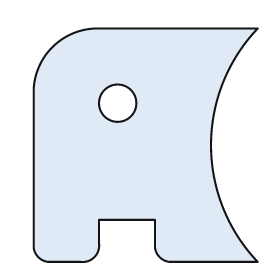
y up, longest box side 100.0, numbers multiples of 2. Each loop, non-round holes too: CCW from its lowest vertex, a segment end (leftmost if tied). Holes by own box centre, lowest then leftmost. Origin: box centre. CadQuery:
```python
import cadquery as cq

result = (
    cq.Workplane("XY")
    .moveTo(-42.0, -50.0)
    .lineTo(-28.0, -50.0)
    .threePointArc((-22.0, -48.0), (-20.0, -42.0))
    .lineTo(-20.0, -32.0)
    .lineTo(4.0, -32.0)
    .lineTo(4.0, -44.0)
    .threePointArc((6.0, -48.0), (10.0, -50.0))
    .lineTo(48.0, -50.0)
    .threePointArc((28.0, 0.0), (48.0, 50.0))
    .lineTo(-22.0, 50.0)
    .threePointArc((-40.0, 42.0), (-48.0, 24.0))
    .lineTo(-48.0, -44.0)
    .threePointArc((-46.0, -48.0), (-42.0, -50.0))
    .close()
    .moveTo(-12.0, 18.0)
    .circle(8.0)
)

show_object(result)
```